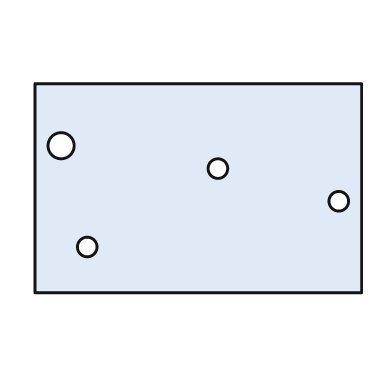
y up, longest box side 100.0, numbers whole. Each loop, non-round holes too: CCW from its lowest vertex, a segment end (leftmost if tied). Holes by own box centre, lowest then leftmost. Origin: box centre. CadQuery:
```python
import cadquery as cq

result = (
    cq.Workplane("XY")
    .moveTo(-50.0, -32.0)
    .lineTo(50.0, -32.0)
    .lineTo(50.0, 32.0)
    .lineTo(-50.0, 32.0)
    .close()
    .moveTo(-34.0, -18.0)
    .circle(3.0)
    .moveTo(43.0, -4.0)
    .circle(3.0)
    .moveTo(6.0, 6.0)
    .circle(3.0)
    .moveTo(-42.0, 13.0)
    .circle(4.0)
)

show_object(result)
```